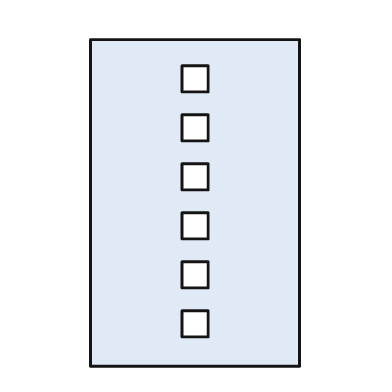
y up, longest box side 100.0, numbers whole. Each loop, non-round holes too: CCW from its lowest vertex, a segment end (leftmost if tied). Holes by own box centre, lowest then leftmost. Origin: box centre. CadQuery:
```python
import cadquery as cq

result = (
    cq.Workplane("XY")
    .moveTo(-32.0, -50.0)
    .lineTo(32.0, -50.0)
    .lineTo(32.0, 50.0)
    .lineTo(-32.0, 50.0)
    .close()
    .moveTo(-4.0, -41.0)
    .lineTo(4.0, -41.0)
    .lineTo(4.0, -33.0)
    .lineTo(-4.0, -33.0)
    .close()
    .moveTo(-4.0, -26.0)
    .lineTo(4.0, -26.0)
    .lineTo(4.0, -18.0)
    .lineTo(-4.0, -18.0)
    .close()
    .moveTo(-4.0, -11.0)
    .lineTo(4.0, -11.0)
    .lineTo(4.0, -3.0)
    .lineTo(-4.0, -3.0)
    .close()
    .moveTo(-4.0, 4.0)
    .lineTo(4.0, 4.0)
    .lineTo(4.0, 12.0)
    .lineTo(-4.0, 12.0)
    .close()
    .moveTo(-4.0, 19.0)
    .lineTo(4.0, 19.0)
    .lineTo(4.0, 27.0)
    .lineTo(-4.0, 27.0)
    .close()
    .moveTo(-4.0, 34.0)
    .lineTo(4.0, 34.0)
    .lineTo(4.0, 42.0)
    .lineTo(-4.0, 42.0)
    .close()
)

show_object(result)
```